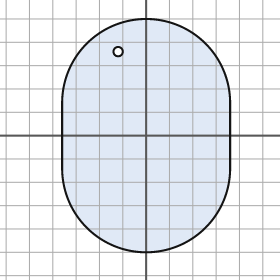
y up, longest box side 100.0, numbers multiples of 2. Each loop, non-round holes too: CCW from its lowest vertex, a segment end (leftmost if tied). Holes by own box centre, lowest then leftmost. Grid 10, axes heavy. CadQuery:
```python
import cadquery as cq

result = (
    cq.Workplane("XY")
    .moveTo(-36.0, -14.0)
    .threePointArc((0.0, -50.0), (36.0, -14.0))
    .lineTo(36.0, 14.0)
    .threePointArc((0.0, 50.0), (-36.0, 14.0))
    .close()
    .moveTo(-12.0, 36.0)
    .circle(2.0)
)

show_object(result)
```